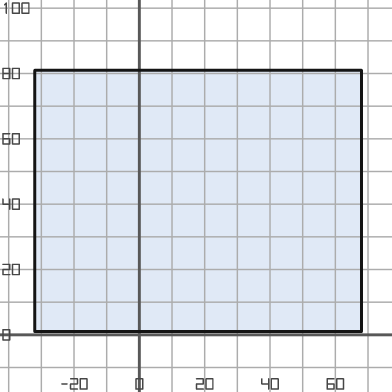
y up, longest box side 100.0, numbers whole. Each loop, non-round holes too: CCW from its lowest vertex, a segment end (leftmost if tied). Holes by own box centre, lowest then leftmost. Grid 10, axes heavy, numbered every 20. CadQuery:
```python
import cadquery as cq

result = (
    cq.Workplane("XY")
    .moveTo(-32.0, 1.0)
    .lineTo(68.0, 1.0)
    .lineTo(68.0, 81.0)
    .lineTo(-32.0, 81.0)
    .close()
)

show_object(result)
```